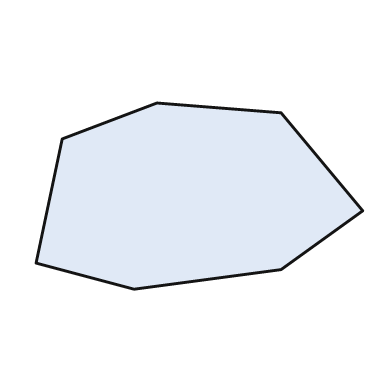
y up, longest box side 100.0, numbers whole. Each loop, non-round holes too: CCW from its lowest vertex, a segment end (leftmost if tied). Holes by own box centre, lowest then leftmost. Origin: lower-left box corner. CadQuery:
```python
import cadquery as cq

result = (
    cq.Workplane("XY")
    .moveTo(30.0, 0.0)
    .lineTo(75.0, 6.0)
    .lineTo(100.0, 24.0)
    .lineTo(75.0, 54.0)
    .lineTo(37.0, 57.0)
    .lineTo(8.0, 46.0)
    .lineTo(0.0, 8.0)
    .close()
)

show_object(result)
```